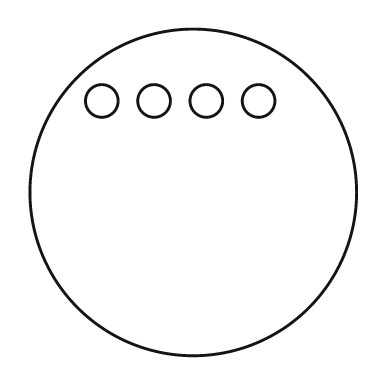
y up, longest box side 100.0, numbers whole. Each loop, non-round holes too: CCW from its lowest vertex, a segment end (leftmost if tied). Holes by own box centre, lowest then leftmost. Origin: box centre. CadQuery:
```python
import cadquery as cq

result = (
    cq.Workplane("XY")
    .moveTo(0.0, 0.0)
    .circle(50.0)
    .moveTo(-28.0, 28.0)
    .circle(5.0)
    .moveTo(-12.0, 28.0)
    .circle(5.0)
    .moveTo(4.0, 28.0)
    .circle(5.0)
    .moveTo(20.0, 28.0)
    .circle(5.0)
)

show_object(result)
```